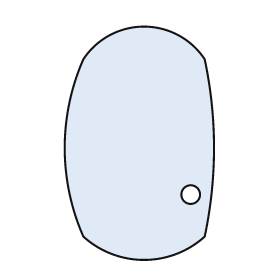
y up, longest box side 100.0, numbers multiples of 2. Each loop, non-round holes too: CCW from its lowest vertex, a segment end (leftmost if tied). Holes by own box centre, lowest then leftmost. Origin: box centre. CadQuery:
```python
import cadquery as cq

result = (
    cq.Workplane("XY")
    .moveTo(-24.0, -40.0)
    .threePointArc((2.0, -50.0), (28.0, -40.0))
    .threePointArc((32.0, -2.0), (28.0, 36.0))
    .threePointArc((2.0, 50.0), (-24.0, 36.0))
    .threePointArc((-32.0, -2.0), (-24.0, -40.0))
    .close()
    .moveTo(22.0, -22.0)
    .circle(4.0)
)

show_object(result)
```